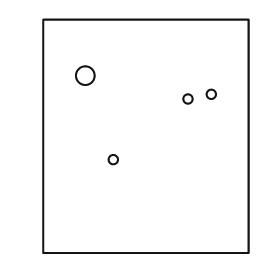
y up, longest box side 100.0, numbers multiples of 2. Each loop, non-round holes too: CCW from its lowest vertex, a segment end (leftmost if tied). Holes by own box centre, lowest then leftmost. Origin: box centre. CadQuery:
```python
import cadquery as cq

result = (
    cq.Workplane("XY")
    .moveTo(-44.0, -50.0)
    .lineTo(44.0, -50.0)
    .lineTo(44.0, 50.0)
    .lineTo(-44.0, 50.0)
    .close()
    .moveTo(-14.0, -10.0)
    .circle(2.0)
    .moveTo(18.0, 16.0)
    .circle(2.0)
    .moveTo(28.0, 18.0)
    .circle(2.0)
    .moveTo(-26.0, 26.0)
    .circle(4.0)
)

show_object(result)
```